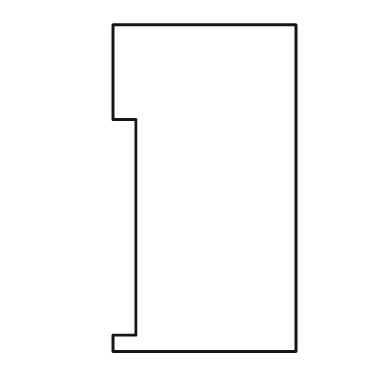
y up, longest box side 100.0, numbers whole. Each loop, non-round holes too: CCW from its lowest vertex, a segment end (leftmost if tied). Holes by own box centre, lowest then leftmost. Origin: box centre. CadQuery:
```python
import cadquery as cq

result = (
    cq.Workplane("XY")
    .moveTo(-28.0, -50.0)
    .lineTo(28.0, -50.0)
    .lineTo(28.0, 50.0)
    .lineTo(-28.0, 50.0)
    .lineTo(-28.0, 21.0)
    .lineTo(-21.0, 21.0)
    .lineTo(-21.0, -45.0)
    .lineTo(-28.0, -45.0)
    .close()
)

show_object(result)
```